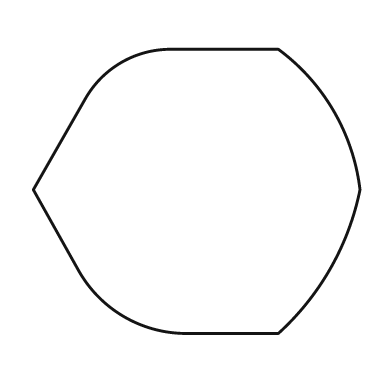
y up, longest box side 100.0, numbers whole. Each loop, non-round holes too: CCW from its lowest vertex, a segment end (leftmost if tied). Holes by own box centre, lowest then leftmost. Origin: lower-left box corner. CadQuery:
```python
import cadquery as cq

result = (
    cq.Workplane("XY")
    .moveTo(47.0, 0.0)
    .lineTo(75.0, 0.0)
    .threePointArc((91.0, 20.0), (100.0, 44.0))
    .threePointArc((92.0, 68.0), (75.0, 87.0))
    .lineTo(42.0, 87.0)
    .threePointArc((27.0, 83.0), (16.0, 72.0))
    .lineTo(0.0, 44.0)
    .lineTo(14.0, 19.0)
    .threePointArc((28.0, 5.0), (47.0, 0.0))
    .close()
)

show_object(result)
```